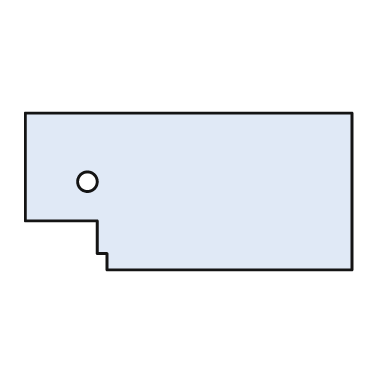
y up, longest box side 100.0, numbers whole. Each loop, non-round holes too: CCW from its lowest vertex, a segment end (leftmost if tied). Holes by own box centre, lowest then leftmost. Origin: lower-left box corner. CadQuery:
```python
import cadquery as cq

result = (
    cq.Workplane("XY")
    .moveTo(25.0, 0.0)
    .lineTo(100.0, 0.0)
    .lineTo(100.0, 48.0)
    .lineTo(0.0, 48.0)
    .lineTo(0.0, 15.0)
    .lineTo(22.0, 15.0)
    .lineTo(22.0, 5.0)
    .lineTo(25.0, 5.0)
    .close()
    .moveTo(19.0, 27.0)
    .circle(3.0)
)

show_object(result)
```